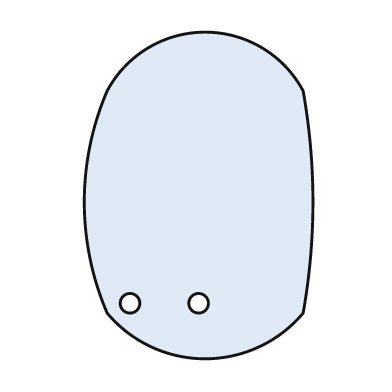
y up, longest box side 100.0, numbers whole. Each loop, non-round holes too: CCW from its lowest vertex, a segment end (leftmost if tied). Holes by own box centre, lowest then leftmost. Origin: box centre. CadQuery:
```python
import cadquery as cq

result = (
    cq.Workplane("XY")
    .moveTo(-28.0, -36.0)
    .threePointArc((2.0, -50.0), (32.0, -36.0))
    .threePointArc((35.0, -2.0), (32.0, 32.0))
    .threePointArc((2.0, 50.0), (-28.0, 32.0))
    .threePointArc((-35.0, -2.0), (-28.0, -36.0))
    .close()
    .moveTo(-21.0, -33.0)
    .circle(3.0)
    .moveTo(0.0, -33.0)
    .circle(3.0)
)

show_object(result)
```